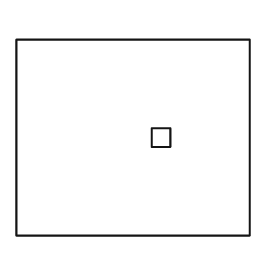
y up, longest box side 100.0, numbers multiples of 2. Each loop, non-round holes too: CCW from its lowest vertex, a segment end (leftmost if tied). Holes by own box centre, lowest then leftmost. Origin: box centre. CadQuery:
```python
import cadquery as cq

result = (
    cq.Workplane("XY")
    .moveTo(-50.0, -42.0)
    .lineTo(50.0, -42.0)
    .lineTo(50.0, 42.0)
    .lineTo(-50.0, 42.0)
    .close()
    .moveTo(8.0, -4.0)
    .lineTo(16.0, -4.0)
    .lineTo(16.0, 4.0)
    .lineTo(8.0, 4.0)
    .close()
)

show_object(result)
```